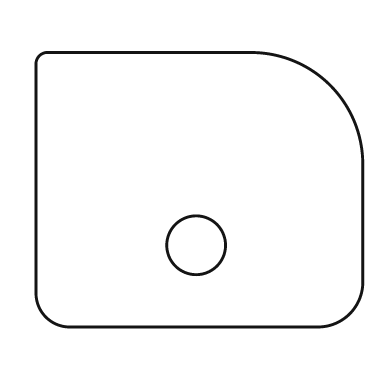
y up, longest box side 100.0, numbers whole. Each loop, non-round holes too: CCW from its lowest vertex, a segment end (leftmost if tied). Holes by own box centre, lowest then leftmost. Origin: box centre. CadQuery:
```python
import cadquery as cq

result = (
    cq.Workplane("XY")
    .moveTo(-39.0, -42.0)
    .lineTo(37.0, -42.0)
    .threePointArc((46.0, -38.0), (50.0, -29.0))
    .lineTo(50.0, 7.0)
    .threePointArc((40.0, 32.0), (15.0, 42.0))
    .lineTo(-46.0, 42.0)
    .threePointArc((-49.0, 41.0), (-50.0, 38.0))
    .lineTo(-50.0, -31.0)
    .threePointArc((-47.0, -39.0), (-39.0, -42.0))
    .close()
    .moveTo(-1.0, -17.0)
    .circle(9.0)
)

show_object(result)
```